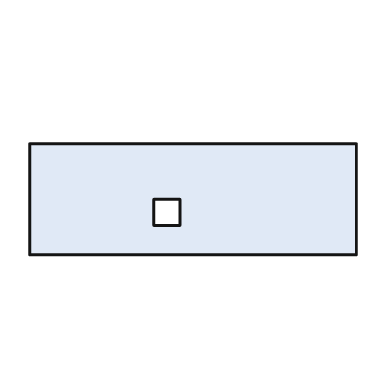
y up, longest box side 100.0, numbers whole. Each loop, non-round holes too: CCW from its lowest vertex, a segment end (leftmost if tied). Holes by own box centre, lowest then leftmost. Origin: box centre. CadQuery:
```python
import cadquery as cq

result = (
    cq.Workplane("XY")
    .moveTo(-50.0, -17.0)
    .lineTo(50.0, -17.0)
    .lineTo(50.0, 17.0)
    .lineTo(-50.0, 17.0)
    .close()
    .moveTo(-12.0, -8.0)
    .lineTo(-4.0, -8.0)
    .lineTo(-4.0, 0.0)
    .lineTo(-12.0, 0.0)
    .close()
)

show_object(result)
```